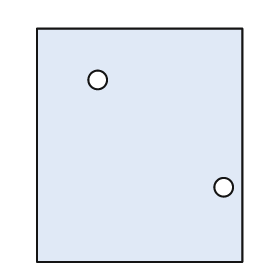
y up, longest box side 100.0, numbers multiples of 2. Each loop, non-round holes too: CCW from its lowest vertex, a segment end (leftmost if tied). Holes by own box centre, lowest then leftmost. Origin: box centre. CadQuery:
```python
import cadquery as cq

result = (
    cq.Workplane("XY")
    .moveTo(-44.0, -50.0)
    .lineTo(44.0, -50.0)
    .lineTo(44.0, 50.0)
    .lineTo(-44.0, 50.0)
    .close()
    .moveTo(36.0, -18.0)
    .circle(4.0)
    .moveTo(-18.0, 28.0)
    .circle(4.0)
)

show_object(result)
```